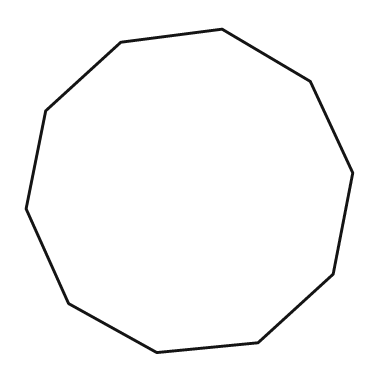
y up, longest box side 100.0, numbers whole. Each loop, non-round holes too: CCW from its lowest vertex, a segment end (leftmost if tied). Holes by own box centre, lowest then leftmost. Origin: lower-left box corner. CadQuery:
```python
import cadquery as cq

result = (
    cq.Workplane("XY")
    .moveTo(40.0, 0.0)
    .lineTo(71.0, 3.0)
    .lineTo(94.0, 24.0)
    .lineTo(100.0, 55.0)
    .lineTo(87.0, 83.0)
    .lineTo(60.0, 99.0)
    .lineTo(29.0, 95.0)
    .lineTo(6.0, 74.0)
    .lineTo(0.0, 44.0)
    .lineTo(13.0, 15.0)
    .close()
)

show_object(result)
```